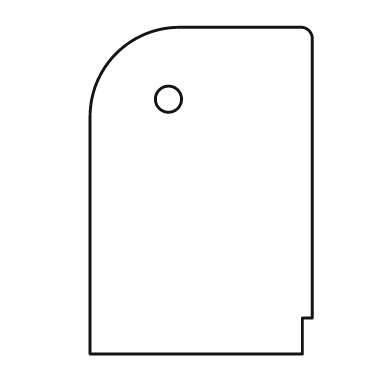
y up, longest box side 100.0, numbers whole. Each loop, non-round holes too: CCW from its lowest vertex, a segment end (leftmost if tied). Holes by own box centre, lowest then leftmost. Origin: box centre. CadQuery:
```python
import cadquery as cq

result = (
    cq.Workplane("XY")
    .moveTo(-34.0, -50.0)
    .lineTo(31.0, -50.0)
    .lineTo(31.0, -39.0)
    .lineTo(34.0, -39.0)
    .lineTo(34.0, 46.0)
    .threePointArc((33.0, 49.0), (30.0, 50.0))
    .lineTo(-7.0, 50.0)
    .threePointArc((-26.0, 42.0), (-34.0, 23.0))
    .close()
    .moveTo(-10.0, 28.0)
    .circle(4.0)
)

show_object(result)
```